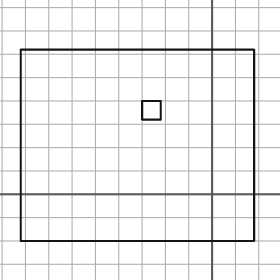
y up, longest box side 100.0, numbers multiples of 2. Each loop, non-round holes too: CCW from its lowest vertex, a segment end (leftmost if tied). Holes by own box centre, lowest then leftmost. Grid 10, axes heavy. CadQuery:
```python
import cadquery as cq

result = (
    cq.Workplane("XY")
    .moveTo(-82.0, -20.0)
    .lineTo(18.0, -20.0)
    .lineTo(18.0, 62.0)
    .lineTo(-82.0, 62.0)
    .close()
    .moveTo(-30.0, 32.0)
    .lineTo(-22.0, 32.0)
    .lineTo(-22.0, 40.0)
    .lineTo(-30.0, 40.0)
    .close()
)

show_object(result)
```